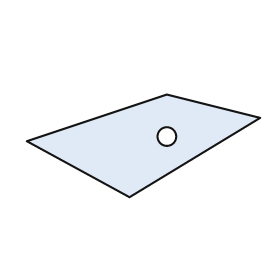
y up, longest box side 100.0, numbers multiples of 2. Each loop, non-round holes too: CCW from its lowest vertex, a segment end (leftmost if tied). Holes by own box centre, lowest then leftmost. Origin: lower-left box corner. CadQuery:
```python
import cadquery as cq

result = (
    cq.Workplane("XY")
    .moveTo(44.0, 0.0)
    .lineTo(100.0, 34.0)
    .lineTo(60.0, 44.0)
    .lineTo(0.0, 24.0)
    .close()
    .moveTo(60.0, 26.0)
    .circle(4.0)
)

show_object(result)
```